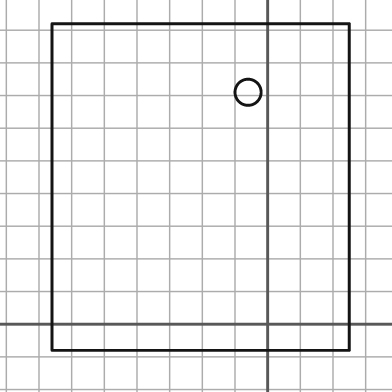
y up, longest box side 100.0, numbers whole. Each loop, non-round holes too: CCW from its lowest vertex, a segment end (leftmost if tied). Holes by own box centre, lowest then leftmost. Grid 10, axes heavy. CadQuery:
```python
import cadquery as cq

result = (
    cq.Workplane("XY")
    .moveTo(-66.0, -8.0)
    .lineTo(25.0, -8.0)
    .lineTo(25.0, 92.0)
    .lineTo(-66.0, 92.0)
    .close()
    .moveTo(-6.0, 71.0)
    .circle(4.0)
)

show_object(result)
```